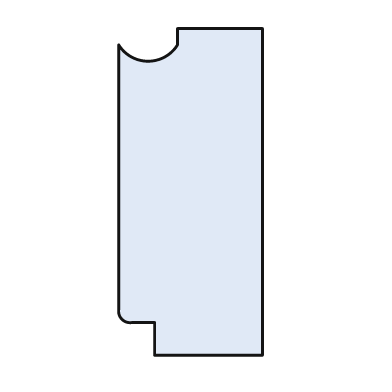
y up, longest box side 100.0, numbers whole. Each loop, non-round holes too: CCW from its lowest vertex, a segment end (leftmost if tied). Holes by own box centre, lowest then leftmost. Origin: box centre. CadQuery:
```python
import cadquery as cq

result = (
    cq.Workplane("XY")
    .moveTo(-11.0, -50.0)
    .lineTo(22.0, -50.0)
    .lineTo(22.0, 50.0)
    .lineTo(-4.0, 50.0)
    .lineTo(-4.0, 45.0)
    .threePointArc((-13.0, 40.0), (-22.0, 45.0))
    .lineTo(-22.0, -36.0)
    .threePointArc((-21.0, -39.0), (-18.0, -40.0))
    .lineTo(-11.0, -40.0)
    .close()
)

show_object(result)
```